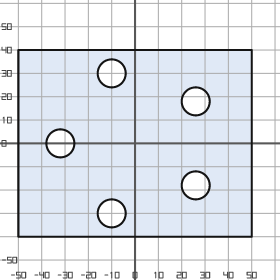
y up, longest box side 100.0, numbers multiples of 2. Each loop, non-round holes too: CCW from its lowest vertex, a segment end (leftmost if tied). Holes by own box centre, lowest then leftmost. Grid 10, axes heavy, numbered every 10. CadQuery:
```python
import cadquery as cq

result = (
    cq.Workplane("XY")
    .moveTo(-50.0, -40.0)
    .lineTo(50.0, -40.0)
    .lineTo(50.0, 40.0)
    .lineTo(-50.0, 40.0)
    .close()
    .moveTo(-10.0, -30.0)
    .circle(6.0)
    .moveTo(26.0, -18.0)
    .circle(6.0)
    .moveTo(-32.0, 0.0)
    .circle(6.0)
    .moveTo(26.0, 18.0)
    .circle(6.0)
    .moveTo(-10.0, 30.0)
    .circle(6.0)
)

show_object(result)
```